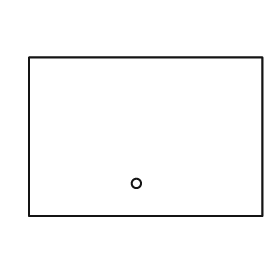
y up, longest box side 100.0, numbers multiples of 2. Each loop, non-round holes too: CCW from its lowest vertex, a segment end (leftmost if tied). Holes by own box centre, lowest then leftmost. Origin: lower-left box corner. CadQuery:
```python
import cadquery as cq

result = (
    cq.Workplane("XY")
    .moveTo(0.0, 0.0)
    .lineTo(100.0, 0.0)
    .lineTo(100.0, 68.0)
    .lineTo(0.0, 68.0)
    .close()
    .moveTo(46.0, 14.0)
    .circle(2.0)
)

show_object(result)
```